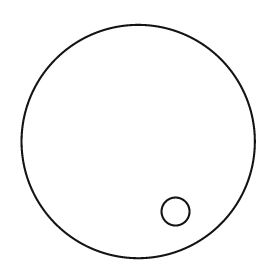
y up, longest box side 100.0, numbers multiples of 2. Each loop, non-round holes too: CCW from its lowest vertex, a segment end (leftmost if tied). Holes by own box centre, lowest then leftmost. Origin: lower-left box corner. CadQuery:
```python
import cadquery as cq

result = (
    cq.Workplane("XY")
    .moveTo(50.0, 50.0)
    .circle(50.0)
    .moveTo(66.0, 20.0)
    .circle(6.0)
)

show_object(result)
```